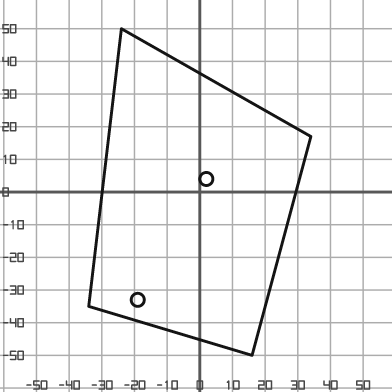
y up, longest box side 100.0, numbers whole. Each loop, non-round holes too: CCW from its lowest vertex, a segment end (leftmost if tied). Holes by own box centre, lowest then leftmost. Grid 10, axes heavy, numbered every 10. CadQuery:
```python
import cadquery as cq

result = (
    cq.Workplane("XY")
    .moveTo(16.0, -50.0)
    .lineTo(34.0, 17.0)
    .lineTo(-24.0, 50.0)
    .lineTo(-34.0, -35.0)
    .close()
    .moveTo(-19.0, -33.0)
    .circle(2.0)
    .moveTo(2.0, 4.0)
    .circle(2.0)
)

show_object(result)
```